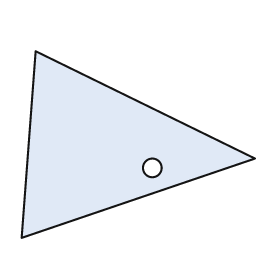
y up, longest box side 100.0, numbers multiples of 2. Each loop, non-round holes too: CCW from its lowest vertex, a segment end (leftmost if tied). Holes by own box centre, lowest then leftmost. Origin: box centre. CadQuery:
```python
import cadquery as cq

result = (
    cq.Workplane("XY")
    .moveTo(-50.0, -40.0)
    .lineTo(50.0, -6.0)
    .lineTo(-44.0, 40.0)
    .close()
    .moveTo(6.0, -10.0)
    .circle(4.0)
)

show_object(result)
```